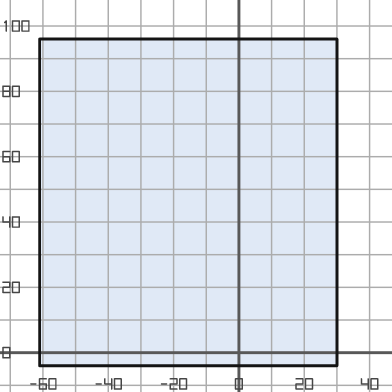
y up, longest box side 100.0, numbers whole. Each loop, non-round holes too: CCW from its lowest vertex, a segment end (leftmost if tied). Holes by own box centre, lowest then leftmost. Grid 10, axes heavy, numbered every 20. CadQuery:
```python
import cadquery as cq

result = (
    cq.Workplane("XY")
    .moveTo(-61.0, -4.0)
    .lineTo(30.0, -4.0)
    .lineTo(30.0, 96.0)
    .lineTo(-61.0, 96.0)
    .close()
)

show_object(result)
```